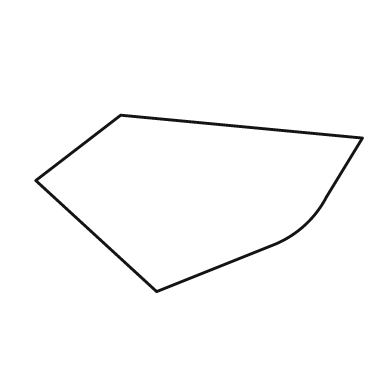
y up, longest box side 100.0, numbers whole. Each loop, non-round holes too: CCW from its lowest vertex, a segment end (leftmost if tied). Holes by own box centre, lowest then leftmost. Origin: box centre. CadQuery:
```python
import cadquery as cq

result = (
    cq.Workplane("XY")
    .moveTo(-13.0, -27.0)
    .lineTo(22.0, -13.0)
    .threePointArc((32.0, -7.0), (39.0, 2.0))
    .lineTo(50.0, 20.0)
    .lineTo(-24.0, 27.0)
    .lineTo(-50.0, 7.0)
    .close()
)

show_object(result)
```